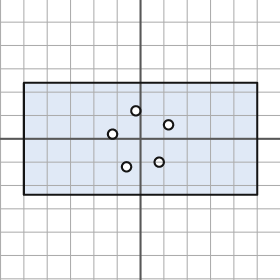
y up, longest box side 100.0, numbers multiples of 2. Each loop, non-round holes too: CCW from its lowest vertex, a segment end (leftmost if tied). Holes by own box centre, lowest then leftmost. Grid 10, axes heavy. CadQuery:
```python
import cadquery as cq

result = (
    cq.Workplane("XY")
    .moveTo(-50.0, -24.0)
    .lineTo(50.0, -24.0)
    .lineTo(50.0, 24.0)
    .lineTo(-50.0, 24.0)
    .close()
    .moveTo(-6.0, -12.0)
    .circle(2.0)
    .moveTo(8.0, -10.0)
    .circle(2.0)
    .moveTo(-12.0, 2.0)
    .circle(2.0)
    .moveTo(12.0, 6.0)
    .circle(2.0)
    .moveTo(-2.0, 12.0)
    .circle(2.0)
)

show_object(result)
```